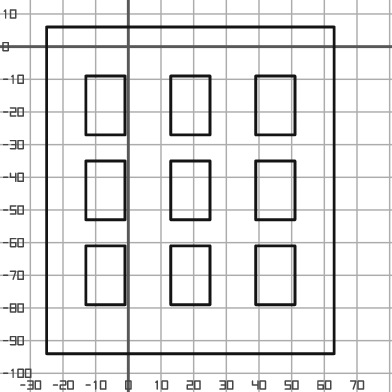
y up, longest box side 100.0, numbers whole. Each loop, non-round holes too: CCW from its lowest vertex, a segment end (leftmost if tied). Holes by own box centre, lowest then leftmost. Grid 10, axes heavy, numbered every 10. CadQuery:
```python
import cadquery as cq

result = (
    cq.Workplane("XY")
    .moveTo(-25.0, -94.0)
    .lineTo(63.0, -94.0)
    .lineTo(63.0, 6.0)
    .lineTo(-25.0, 6.0)
    .close()
    .moveTo(-13.0, -79.0)
    .lineTo(-1.0, -79.0)
    .lineTo(-1.0, -61.0)
    .lineTo(-13.0, -61.0)
    .close()
    .moveTo(13.0, -79.0)
    .lineTo(25.0, -79.0)
    .lineTo(25.0, -61.0)
    .lineTo(13.0, -61.0)
    .close()
    .moveTo(39.0, -79.0)
    .lineTo(51.0, -79.0)
    .lineTo(51.0, -61.0)
    .lineTo(39.0, -61.0)
    .close()
    .moveTo(-13.0, -53.0)
    .lineTo(-1.0, -53.0)
    .lineTo(-1.0, -35.0)
    .lineTo(-13.0, -35.0)
    .close()
    .moveTo(13.0, -53.0)
    .lineTo(25.0, -53.0)
    .lineTo(25.0, -35.0)
    .lineTo(13.0, -35.0)
    .close()
    .moveTo(39.0, -53.0)
    .lineTo(51.0, -53.0)
    .lineTo(51.0, -35.0)
    .lineTo(39.0, -35.0)
    .close()
    .moveTo(-13.0, -27.0)
    .lineTo(-1.0, -27.0)
    .lineTo(-1.0, -9.0)
    .lineTo(-13.0, -9.0)
    .close()
    .moveTo(13.0, -27.0)
    .lineTo(25.0, -27.0)
    .lineTo(25.0, -9.0)
    .lineTo(13.0, -9.0)
    .close()
    .moveTo(39.0, -27.0)
    .lineTo(51.0, -27.0)
    .lineTo(51.0, -9.0)
    .lineTo(39.0, -9.0)
    .close()
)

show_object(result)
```